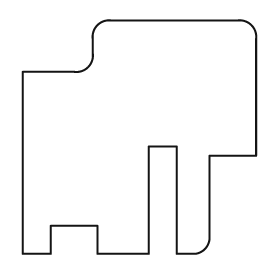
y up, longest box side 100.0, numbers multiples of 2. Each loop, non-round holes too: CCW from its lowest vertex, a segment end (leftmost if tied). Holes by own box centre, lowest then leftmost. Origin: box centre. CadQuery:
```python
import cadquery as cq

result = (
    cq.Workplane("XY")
    .moveTo(-50.0, -50.0)
    .lineTo(-38.0, -50.0)
    .lineTo(-38.0, -38.0)
    .lineTo(-18.0, -38.0)
    .lineTo(-18.0, -50.0)
    .lineTo(4.0, -50.0)
    .lineTo(4.0, -4.0)
    .lineTo(16.0, -4.0)
    .lineTo(16.0, -50.0)
    .lineTo(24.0, -50.0)
    .threePointArc((28.0, -48.0), (30.0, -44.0))
    .lineTo(30.0, -8.0)
    .lineTo(50.0, -8.0)
    .lineTo(50.0, 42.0)
    .threePointArc((48.0, 48.0), (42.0, 50.0))
    .lineTo(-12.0, 50.0)
    .threePointArc((-18.0, 48.0), (-20.0, 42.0))
    .lineTo(-20.0, 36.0)
    .threePointArc((-22.0, 30.0), (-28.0, 28.0))
    .lineTo(-50.0, 28.0)
    .close()
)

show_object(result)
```